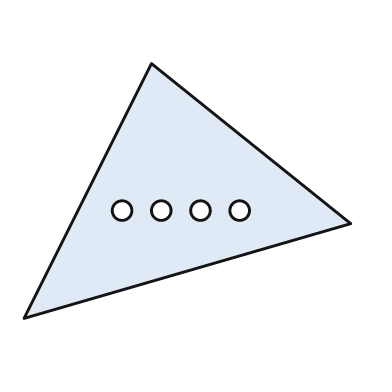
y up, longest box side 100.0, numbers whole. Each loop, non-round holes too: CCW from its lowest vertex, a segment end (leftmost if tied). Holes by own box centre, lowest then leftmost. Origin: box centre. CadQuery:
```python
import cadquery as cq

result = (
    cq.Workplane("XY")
    .moveTo(-50.0, -39.0)
    .lineTo(50.0, -10.0)
    .lineTo(-11.0, 39.0)
    .close()
    .moveTo(-20.0, -6.0)
    .circle(3.0)
    .moveTo(-8.0, -6.0)
    .circle(3.0)
    .moveTo(4.0, -6.0)
    .circle(3.0)
    .moveTo(16.0, -6.0)
    .circle(3.0)
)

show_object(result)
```